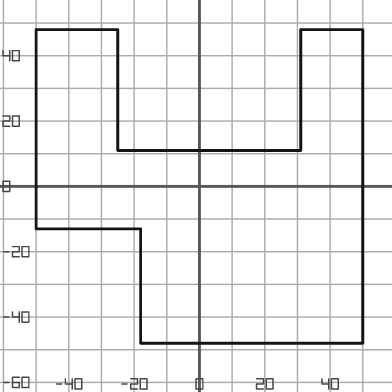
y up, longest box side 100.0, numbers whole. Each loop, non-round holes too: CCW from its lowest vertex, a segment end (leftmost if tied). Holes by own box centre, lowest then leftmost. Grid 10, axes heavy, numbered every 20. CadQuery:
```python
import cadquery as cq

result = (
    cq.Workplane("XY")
    .moveTo(-18.0, -48.0)
    .lineTo(50.0, -48.0)
    .lineTo(50.0, 48.0)
    .lineTo(31.0, 48.0)
    .lineTo(31.0, 11.0)
    .lineTo(-25.0, 11.0)
    .lineTo(-25.0, 48.0)
    .lineTo(-50.0, 48.0)
    .lineTo(-50.0, -13.0)
    .lineTo(-18.0, -13.0)
    .close()
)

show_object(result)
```